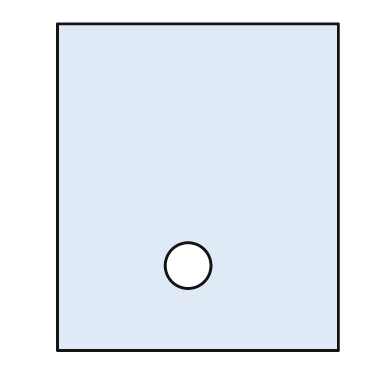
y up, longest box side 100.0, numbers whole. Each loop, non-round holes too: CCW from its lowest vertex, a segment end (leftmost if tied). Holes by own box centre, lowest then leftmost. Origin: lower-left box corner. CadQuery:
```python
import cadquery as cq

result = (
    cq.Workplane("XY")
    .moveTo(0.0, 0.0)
    .lineTo(86.0, 0.0)
    .lineTo(86.0, 100.0)
    .lineTo(0.0, 100.0)
    .close()
    .moveTo(40.0, 26.0)
    .circle(7.0)
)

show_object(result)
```